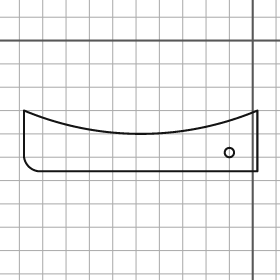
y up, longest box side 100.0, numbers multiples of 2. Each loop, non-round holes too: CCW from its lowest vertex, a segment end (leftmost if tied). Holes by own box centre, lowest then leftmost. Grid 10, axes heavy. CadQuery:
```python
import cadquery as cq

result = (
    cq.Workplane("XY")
    .moveTo(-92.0, -56.0)
    .lineTo(2.0, -56.0)
    .lineTo(2.0, -30.0)
    .threePointArc((-48.0, -40.0), (-98.0, -30.0))
    .lineTo(-98.0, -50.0)
    .threePointArc((-96.0, -54.0), (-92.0, -56.0))
    .close()
    .moveTo(-10.0, -48.0)
    .circle(2.0)
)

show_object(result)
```